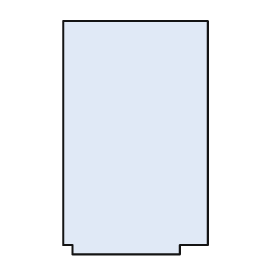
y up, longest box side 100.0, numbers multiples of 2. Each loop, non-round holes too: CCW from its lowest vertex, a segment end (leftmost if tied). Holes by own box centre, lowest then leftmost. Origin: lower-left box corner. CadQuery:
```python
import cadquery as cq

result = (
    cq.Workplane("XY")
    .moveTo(4.0, 0.0)
    .lineTo(50.0, 0.0)
    .lineTo(50.0, 4.0)
    .lineTo(62.0, 4.0)
    .lineTo(62.0, 100.0)
    .lineTo(0.0, 100.0)
    .lineTo(0.0, 4.0)
    .lineTo(4.0, 4.0)
    .close()
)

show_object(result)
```